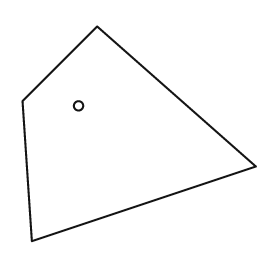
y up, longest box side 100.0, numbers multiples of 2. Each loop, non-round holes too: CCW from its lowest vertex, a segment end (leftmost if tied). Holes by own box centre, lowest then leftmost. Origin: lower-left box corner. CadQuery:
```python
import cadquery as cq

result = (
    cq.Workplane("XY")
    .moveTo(4.0, 0.0)
    .lineTo(100.0, 32.0)
    .lineTo(32.0, 92.0)
    .lineTo(0.0, 60.0)
    .close()
    .moveTo(24.0, 58.0)
    .circle(2.0)
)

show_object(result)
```